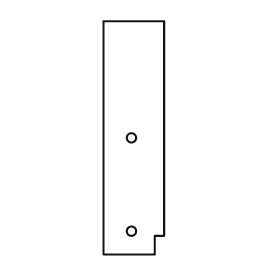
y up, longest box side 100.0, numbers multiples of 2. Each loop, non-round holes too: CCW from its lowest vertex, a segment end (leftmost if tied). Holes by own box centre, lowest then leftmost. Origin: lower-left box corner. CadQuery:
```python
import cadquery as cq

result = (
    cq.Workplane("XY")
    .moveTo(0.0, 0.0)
    .lineTo(22.0, 0.0)
    .lineTo(22.0, 8.0)
    .lineTo(26.0, 8.0)
    .lineTo(26.0, 100.0)
    .lineTo(0.0, 100.0)
    .close()
    .moveTo(12.0, 10.0)
    .circle(2.0)
    .moveTo(12.0, 50.0)
    .circle(2.0)
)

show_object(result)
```